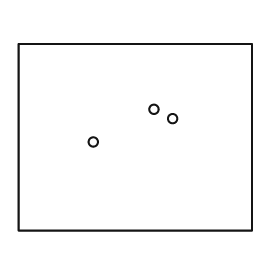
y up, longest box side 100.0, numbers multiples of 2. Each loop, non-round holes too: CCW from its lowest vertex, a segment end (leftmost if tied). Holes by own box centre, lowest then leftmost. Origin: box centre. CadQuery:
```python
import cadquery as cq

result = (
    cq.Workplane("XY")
    .moveTo(-50.0, -40.0)
    .lineTo(50.0, -40.0)
    .lineTo(50.0, 40.0)
    .lineTo(-50.0, 40.0)
    .close()
    .moveTo(-18.0, -2.0)
    .circle(2.0)
    .moveTo(16.0, 8.0)
    .circle(2.0)
    .moveTo(8.0, 12.0)
    .circle(2.0)
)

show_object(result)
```